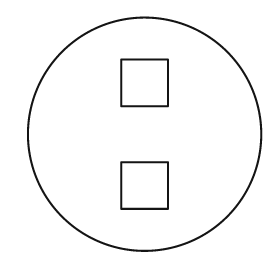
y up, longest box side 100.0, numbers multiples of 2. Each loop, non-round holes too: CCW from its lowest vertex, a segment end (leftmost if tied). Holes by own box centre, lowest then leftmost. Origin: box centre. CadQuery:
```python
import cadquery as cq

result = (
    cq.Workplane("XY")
    .moveTo(0.0, 0.0)
    .circle(50.0)
    .moveTo(-10.0, -32.0)
    .lineTo(10.0, -32.0)
    .lineTo(10.0, -12.0)
    .lineTo(-10.0, -12.0)
    .close()
    .moveTo(-10.0, 12.0)
    .lineTo(10.0, 12.0)
    .lineTo(10.0, 32.0)
    .lineTo(-10.0, 32.0)
    .close()
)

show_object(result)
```